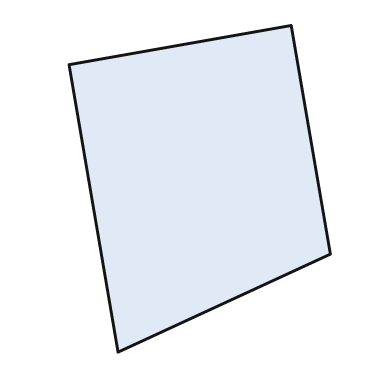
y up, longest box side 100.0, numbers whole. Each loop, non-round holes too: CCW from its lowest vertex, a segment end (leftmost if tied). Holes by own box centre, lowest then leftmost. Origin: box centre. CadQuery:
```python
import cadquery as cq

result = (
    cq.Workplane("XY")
    .moveTo(-25.0, -50.0)
    .lineTo(40.0, -20.0)
    .lineTo(28.0, 50.0)
    .lineTo(-40.0, 38.0)
    .close()
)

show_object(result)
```